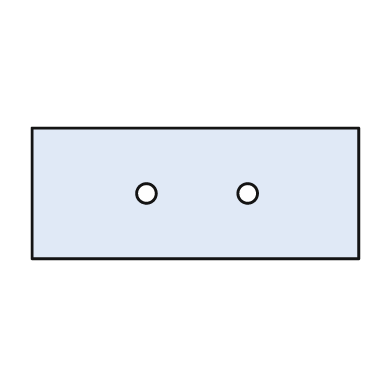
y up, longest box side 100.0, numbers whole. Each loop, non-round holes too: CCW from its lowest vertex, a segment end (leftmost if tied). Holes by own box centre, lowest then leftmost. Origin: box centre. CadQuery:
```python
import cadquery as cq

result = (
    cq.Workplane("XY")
    .moveTo(-50.0, -20.0)
    .lineTo(50.0, -20.0)
    .lineTo(50.0, 20.0)
    .lineTo(-50.0, 20.0)
    .close()
    .moveTo(-15.0, 0.0)
    .circle(3.0)
    .moveTo(16.0, 0.0)
    .circle(3.0)
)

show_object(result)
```